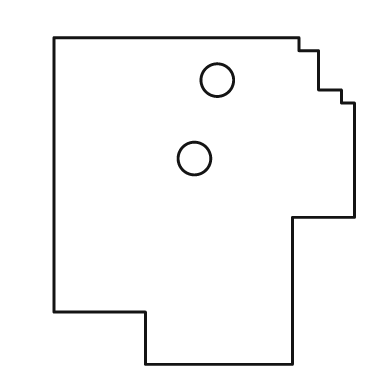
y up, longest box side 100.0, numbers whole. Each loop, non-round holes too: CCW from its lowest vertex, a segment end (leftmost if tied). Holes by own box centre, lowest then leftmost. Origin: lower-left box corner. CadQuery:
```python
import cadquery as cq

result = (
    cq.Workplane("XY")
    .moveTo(28.0, 0.0)
    .lineTo(73.0, 0.0)
    .lineTo(73.0, 45.0)
    .lineTo(92.0, 45.0)
    .lineTo(92.0, 80.0)
    .lineTo(88.0, 80.0)
    .lineTo(88.0, 84.0)
    .lineTo(81.0, 84.0)
    .lineTo(81.0, 96.0)
    .lineTo(75.0, 96.0)
    .lineTo(75.0, 100.0)
    .lineTo(0.0, 100.0)
    .lineTo(0.0, 16.0)
    .lineTo(28.0, 16.0)
    .close()
    .moveTo(43.0, 63.0)
    .circle(5.0)
    .moveTo(50.0, 87.0)
    .circle(5.0)
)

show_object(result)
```